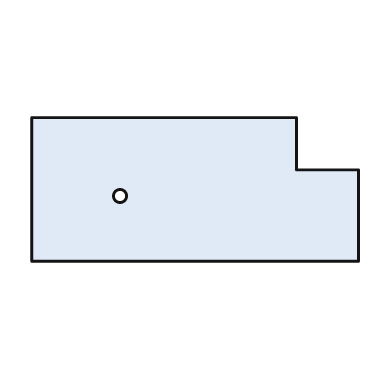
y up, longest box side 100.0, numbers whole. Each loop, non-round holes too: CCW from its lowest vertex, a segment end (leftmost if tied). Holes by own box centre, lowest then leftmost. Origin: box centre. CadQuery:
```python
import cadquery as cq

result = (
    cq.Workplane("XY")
    .moveTo(-50.0, -22.0)
    .lineTo(50.0, -22.0)
    .lineTo(50.0, 6.0)
    .lineTo(31.0, 6.0)
    .lineTo(31.0, 22.0)
    .lineTo(-50.0, 22.0)
    .close()
    .moveTo(-23.0, -2.0)
    .circle(2.0)
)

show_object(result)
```